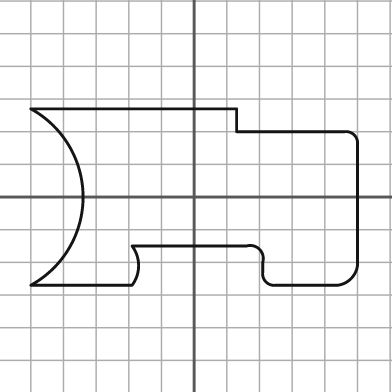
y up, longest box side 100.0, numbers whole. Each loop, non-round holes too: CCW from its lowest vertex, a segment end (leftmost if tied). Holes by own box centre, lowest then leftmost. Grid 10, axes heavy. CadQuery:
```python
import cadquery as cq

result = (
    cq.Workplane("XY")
    .moveTo(-50.0, -27.0)
    .lineTo(-19.0, -27.0)
    .threePointArc((-17.0, -21.0), (-19.0, -15.0))
    .lineTo(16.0, -15.0)
    .threePointArc((20.0, -16.0), (21.0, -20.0))
    .lineTo(21.0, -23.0)
    .threePointArc((22.0, -26.0), (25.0, -27.0))
    .lineTo(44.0, -27.0)
    .threePointArc((48.0, -25.0), (50.0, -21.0))
    .lineTo(50.0, 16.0)
    .threePointArc((49.0, 19.0), (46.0, 20.0))
    .lineTo(13.0, 20.0)
    .lineTo(13.0, 27.0)
    .lineTo(-50.0, 27.0)
    .threePointArc((-34.0, 0.0), (-50.0, -27.0))
    .close()
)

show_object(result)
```